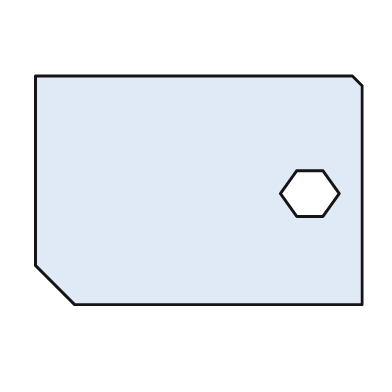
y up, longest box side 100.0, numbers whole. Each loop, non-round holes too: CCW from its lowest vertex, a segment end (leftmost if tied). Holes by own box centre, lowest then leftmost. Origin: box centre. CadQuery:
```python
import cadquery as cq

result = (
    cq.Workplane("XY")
    .moveTo(-38.0, -35.0)
    .lineTo(50.0, -35.0)
    .lineTo(50.0, 32.0)
    .lineTo(47.0, 35.0)
    .lineTo(-50.0, 35.0)
    .lineTo(-50.0, -23.0)
    .close()
    .moveTo(30.0, -8.0)
    .lineTo(38.0, -8.0)
    .lineTo(43.0, -1.0)
    .lineTo(38.0, 6.0)
    .lineTo(30.0, 6.0)
    .lineTo(25.0, -1.0)
    .close()
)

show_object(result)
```